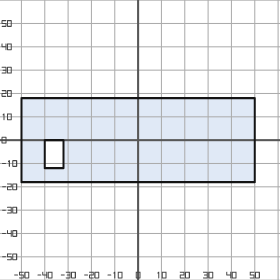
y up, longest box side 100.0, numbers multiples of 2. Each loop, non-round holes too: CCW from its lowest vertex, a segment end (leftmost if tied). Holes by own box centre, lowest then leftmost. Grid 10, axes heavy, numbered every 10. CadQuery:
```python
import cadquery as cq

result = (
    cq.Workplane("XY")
    .moveTo(-50.0, -18.0)
    .lineTo(50.0, -18.0)
    .lineTo(50.0, 18.0)
    .lineTo(-50.0, 18.0)
    .close()
    .moveTo(-40.0, -12.0)
    .lineTo(-32.0, -12.0)
    .lineTo(-32.0, 0.0)
    .lineTo(-40.0, 0.0)
    .close()
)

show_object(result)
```